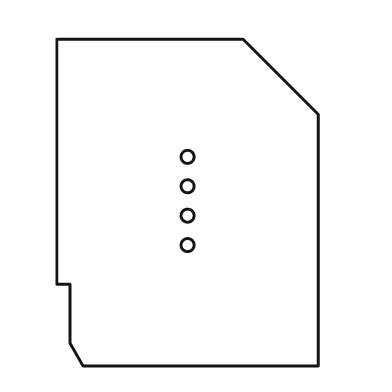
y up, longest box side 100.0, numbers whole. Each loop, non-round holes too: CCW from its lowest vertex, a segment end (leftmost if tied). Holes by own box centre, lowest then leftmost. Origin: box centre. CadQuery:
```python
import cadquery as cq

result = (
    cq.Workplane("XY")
    .moveTo(-32.0, -50.0)
    .lineTo(40.0, -50.0)
    .lineTo(40.0, 27.0)
    .lineTo(17.0, 50.0)
    .lineTo(-40.0, 50.0)
    .lineTo(-40.0, -25.0)
    .lineTo(-36.0, -25.0)
    .lineTo(-36.0, -43.0)
    .close()
    .moveTo(0.0, -13.0)
    .circle(2.0)
    .moveTo(0.0, -4.0)
    .circle(2.0)
    .moveTo(0.0, 5.0)
    .circle(2.0)
    .moveTo(0.0, 14.0)
    .circle(2.0)
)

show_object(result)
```